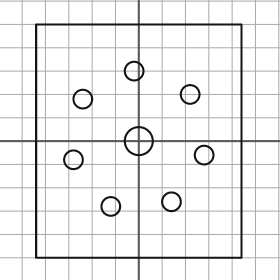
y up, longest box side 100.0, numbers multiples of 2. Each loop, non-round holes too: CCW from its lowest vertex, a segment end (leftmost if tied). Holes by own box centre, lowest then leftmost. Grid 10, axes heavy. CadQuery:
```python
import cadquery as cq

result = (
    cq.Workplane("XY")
    .moveTo(-44.0, -50.0)
    .lineTo(44.0, -50.0)
    .lineTo(44.0, 50.0)
    .lineTo(-44.0, 50.0)
    .close()
    .moveTo(-12.0, -28.0)
    .circle(4.0)
    .moveTo(14.0, -26.0)
    .circle(4.0)
    .moveTo(-28.0, -8.0)
    .circle(4.0)
    .moveTo(28.0, -6.0)
    .circle(4.0)
    .moveTo(0.0, 0.0)
    .circle(6.0)
    .moveTo(-24.0, 18.0)
    .circle(4.0)
    .moveTo(22.0, 20.0)
    .circle(4.0)
    .moveTo(-2.0, 30.0)
    .circle(4.0)
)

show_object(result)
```